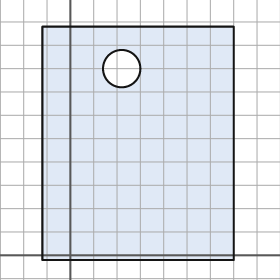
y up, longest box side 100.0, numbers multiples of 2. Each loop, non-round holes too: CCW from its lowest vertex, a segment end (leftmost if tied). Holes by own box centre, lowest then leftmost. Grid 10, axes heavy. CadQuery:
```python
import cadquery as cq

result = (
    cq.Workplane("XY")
    .moveTo(-12.0, -2.0)
    .lineTo(70.0, -2.0)
    .lineTo(70.0, 98.0)
    .lineTo(-12.0, 98.0)
    .close()
    .moveTo(22.0, 80.0)
    .circle(8.0)
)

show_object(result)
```